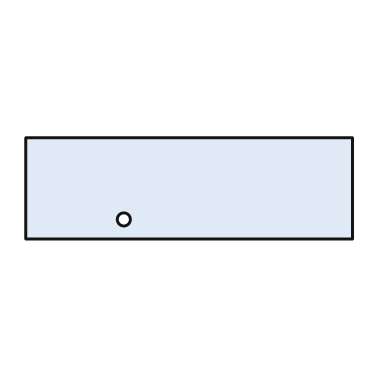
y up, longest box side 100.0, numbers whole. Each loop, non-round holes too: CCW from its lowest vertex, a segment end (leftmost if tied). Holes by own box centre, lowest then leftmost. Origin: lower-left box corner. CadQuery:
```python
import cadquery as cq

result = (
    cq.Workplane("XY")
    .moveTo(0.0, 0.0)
    .lineTo(100.0, 0.0)
    .lineTo(100.0, 31.0)
    .lineTo(0.0, 31.0)
    .close()
    .moveTo(30.0, 6.0)
    .circle(2.0)
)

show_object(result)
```